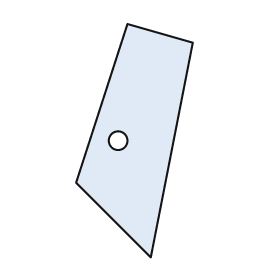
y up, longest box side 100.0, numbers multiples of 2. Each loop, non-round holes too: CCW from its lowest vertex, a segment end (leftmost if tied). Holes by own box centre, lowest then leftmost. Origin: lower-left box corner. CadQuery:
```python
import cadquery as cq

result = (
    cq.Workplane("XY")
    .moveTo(32.0, 0.0)
    .lineTo(50.0, 92.0)
    .lineTo(22.0, 100.0)
    .lineTo(0.0, 32.0)
    .close()
    .moveTo(18.0, 50.0)
    .circle(4.0)
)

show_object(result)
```